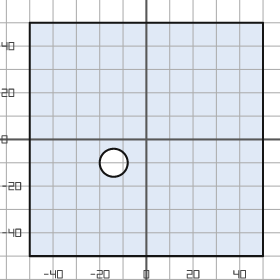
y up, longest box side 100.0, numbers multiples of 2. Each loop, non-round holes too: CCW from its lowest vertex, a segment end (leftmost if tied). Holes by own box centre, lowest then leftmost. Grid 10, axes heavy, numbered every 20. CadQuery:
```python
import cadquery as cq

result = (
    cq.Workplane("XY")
    .moveTo(-50.0, -50.0)
    .lineTo(50.0, -50.0)
    .lineTo(50.0, 50.0)
    .lineTo(-50.0, 50.0)
    .close()
    .moveTo(-14.0, -10.0)
    .circle(6.0)
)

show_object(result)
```